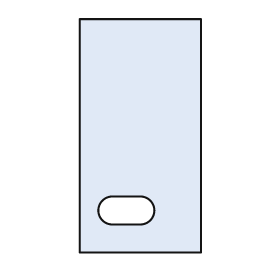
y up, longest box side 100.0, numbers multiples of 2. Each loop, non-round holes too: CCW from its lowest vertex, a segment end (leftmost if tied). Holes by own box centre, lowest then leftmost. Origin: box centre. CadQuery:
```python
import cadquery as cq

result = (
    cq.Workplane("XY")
    .moveTo(-26.0, -50.0)
    .lineTo(26.0, -50.0)
    .lineTo(26.0, 50.0)
    .lineTo(-26.0, 50.0)
    .close()
    .moveTo(-12.0, -38.0)
    .lineTo(0.0, -38.0)
    .threePointArc((6.0, -32.0), (0.0, -26.0))
    .lineTo(-12.0, -26.0)
    .threePointArc((-18.0, -32.0), (-12.0, -38.0))
    .close()
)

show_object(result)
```